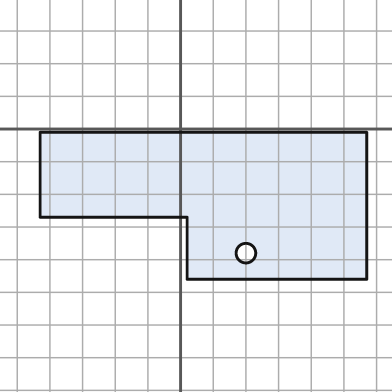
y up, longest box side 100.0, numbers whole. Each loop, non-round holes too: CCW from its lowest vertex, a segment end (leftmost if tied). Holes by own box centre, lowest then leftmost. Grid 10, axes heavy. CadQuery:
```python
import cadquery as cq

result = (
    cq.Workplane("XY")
    .moveTo(2.0, -46.0)
    .lineTo(57.0, -46.0)
    .lineTo(57.0, -1.0)
    .lineTo(-43.0, -1.0)
    .lineTo(-43.0, -27.0)
    .lineTo(2.0, -27.0)
    .close()
    .moveTo(20.0, -38.0)
    .circle(3.0)
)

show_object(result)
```